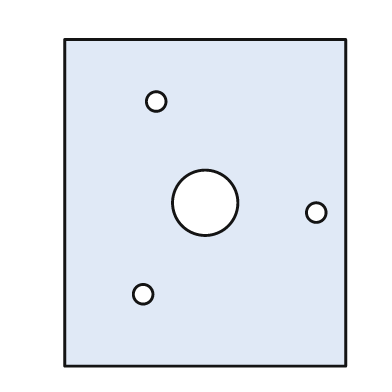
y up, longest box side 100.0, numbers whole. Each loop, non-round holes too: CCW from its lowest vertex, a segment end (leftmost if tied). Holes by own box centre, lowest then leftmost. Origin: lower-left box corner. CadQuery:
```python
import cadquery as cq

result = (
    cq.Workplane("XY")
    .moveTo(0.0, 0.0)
    .lineTo(86.0, 0.0)
    .lineTo(86.0, 100.0)
    .lineTo(0.0, 100.0)
    .close()
    .moveTo(24.0, 22.0)
    .circle(3.0)
    .moveTo(77.0, 47.0)
    .circle(3.0)
    .moveTo(43.0, 50.0)
    .circle(10.0)
    .moveTo(28.0, 81.0)
    .circle(3.0)
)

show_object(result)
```